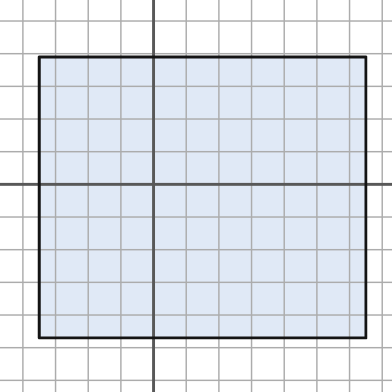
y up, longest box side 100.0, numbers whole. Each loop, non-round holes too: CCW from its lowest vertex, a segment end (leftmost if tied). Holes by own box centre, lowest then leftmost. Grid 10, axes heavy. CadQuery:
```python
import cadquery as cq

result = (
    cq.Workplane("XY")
    .moveTo(-35.0, -47.0)
    .lineTo(65.0, -47.0)
    .lineTo(65.0, 39.0)
    .lineTo(-35.0, 39.0)
    .close()
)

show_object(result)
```